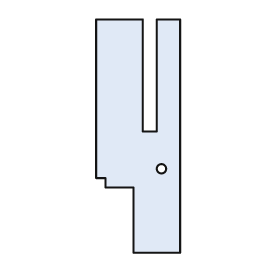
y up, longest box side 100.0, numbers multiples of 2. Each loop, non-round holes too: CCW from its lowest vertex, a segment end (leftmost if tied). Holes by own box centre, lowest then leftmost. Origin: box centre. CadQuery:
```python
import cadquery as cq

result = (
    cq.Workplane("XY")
    .moveTo(-2.0, -50.0)
    .lineTo(18.0, -50.0)
    .lineTo(18.0, 50.0)
    .lineTo(8.0, 50.0)
    .lineTo(8.0, 2.0)
    .lineTo(2.0, 2.0)
    .lineTo(2.0, 50.0)
    .lineTo(-18.0, 50.0)
    .lineTo(-18.0, -18.0)
    .lineTo(-14.0, -18.0)
    .lineTo(-14.0, -22.0)
    .lineTo(-2.0, -22.0)
    .close()
    .moveTo(10.0, -14.0)
    .circle(2.0)
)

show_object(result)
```